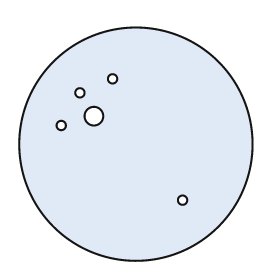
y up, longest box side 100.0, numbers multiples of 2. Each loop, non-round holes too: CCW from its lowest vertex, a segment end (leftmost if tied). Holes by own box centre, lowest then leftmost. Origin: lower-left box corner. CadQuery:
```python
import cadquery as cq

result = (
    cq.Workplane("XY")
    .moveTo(50.0, 50.0)
    .circle(50.0)
    .moveTo(70.0, 26.0)
    .circle(2.0)
    .moveTo(18.0, 58.0)
    .circle(2.0)
    .moveTo(32.0, 62.0)
    .circle(4.0)
    .moveTo(26.0, 72.0)
    .circle(2.0)
    .moveTo(40.0, 78.0)
    .circle(2.0)
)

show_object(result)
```